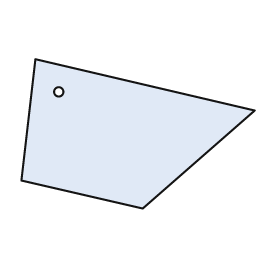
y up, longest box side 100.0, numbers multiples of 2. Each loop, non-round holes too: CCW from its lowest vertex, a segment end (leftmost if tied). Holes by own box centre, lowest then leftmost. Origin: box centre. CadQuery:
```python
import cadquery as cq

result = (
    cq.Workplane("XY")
    .moveTo(2.0, -32.0)
    .lineTo(50.0, 10.0)
    .lineTo(-44.0, 32.0)
    .lineTo(-50.0, -20.0)
    .close()
    .moveTo(-34.0, 18.0)
    .circle(2.0)
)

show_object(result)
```